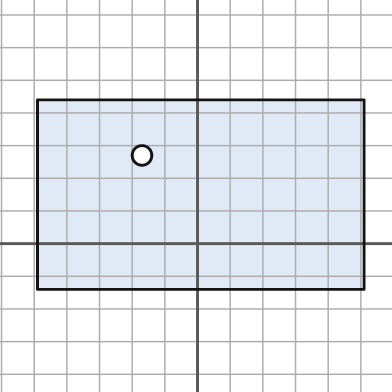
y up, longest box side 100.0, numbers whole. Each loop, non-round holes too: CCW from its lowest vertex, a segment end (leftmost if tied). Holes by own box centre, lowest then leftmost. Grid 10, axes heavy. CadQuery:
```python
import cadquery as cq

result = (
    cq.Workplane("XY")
    .moveTo(-49.0, -14.0)
    .lineTo(51.0, -14.0)
    .lineTo(51.0, 44.0)
    .lineTo(-49.0, 44.0)
    .close()
    .moveTo(-17.0, 27.0)
    .circle(3.0)
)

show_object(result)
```